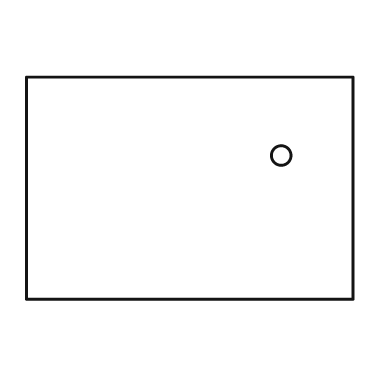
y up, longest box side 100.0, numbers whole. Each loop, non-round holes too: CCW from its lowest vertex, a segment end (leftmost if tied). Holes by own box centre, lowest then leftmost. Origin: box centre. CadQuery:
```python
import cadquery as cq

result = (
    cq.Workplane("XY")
    .moveTo(-50.0, -34.0)
    .lineTo(50.0, -34.0)
    .lineTo(50.0, 34.0)
    .lineTo(-50.0, 34.0)
    .close()
    .moveTo(28.0, 10.0)
    .circle(3.0)
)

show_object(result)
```